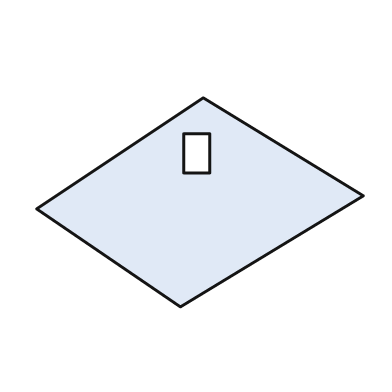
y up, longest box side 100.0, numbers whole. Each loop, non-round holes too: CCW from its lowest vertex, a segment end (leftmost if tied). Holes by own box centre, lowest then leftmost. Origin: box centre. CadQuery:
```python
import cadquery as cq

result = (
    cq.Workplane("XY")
    .moveTo(-6.0, -32.0)
    .lineTo(50.0, 2.0)
    .lineTo(1.0, 32.0)
    .lineTo(-50.0, -2.0)
    .close()
    .moveTo(-5.0, 9.0)
    .lineTo(3.0, 9.0)
    .lineTo(3.0, 21.0)
    .lineTo(-5.0, 21.0)
    .close()
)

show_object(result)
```